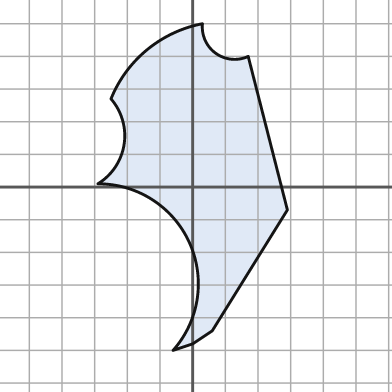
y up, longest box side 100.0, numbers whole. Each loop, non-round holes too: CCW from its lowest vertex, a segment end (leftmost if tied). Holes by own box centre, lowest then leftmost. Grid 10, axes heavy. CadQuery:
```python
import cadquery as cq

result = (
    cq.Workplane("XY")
    .moveTo(-6.0, -50.0)
    .lineTo(0.0, -48.0)
    .lineTo(6.0, -44.0)
    .lineTo(29.0, -7.0)
    .lineTo(17.0, 40.0)
    .threePointArc((7.0, 41.0), (3.0, 50.0))
    .threePointArc((-14.0, 42.0), (-25.0, 27.0))
    .threePointArc((-21.0, 13.0), (-29.0, 1.0))
    .threePointArc((-1.0, -17.0), (-6.0, -50.0))
    .close()
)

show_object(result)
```